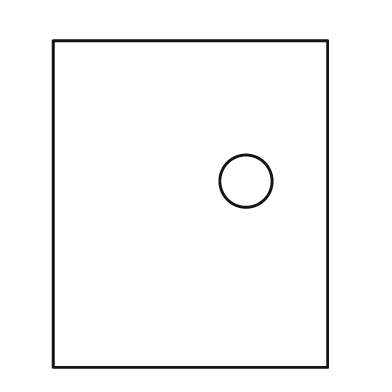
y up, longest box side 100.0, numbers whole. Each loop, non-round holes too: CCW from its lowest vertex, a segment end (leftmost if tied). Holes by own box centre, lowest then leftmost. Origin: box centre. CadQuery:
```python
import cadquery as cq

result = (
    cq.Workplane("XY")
    .moveTo(-42.0, -50.0)
    .lineTo(42.0, -50.0)
    .lineTo(42.0, 50.0)
    .lineTo(-42.0, 50.0)
    .close()
    .moveTo(17.0, 7.0)
    .circle(8.0)
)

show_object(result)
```